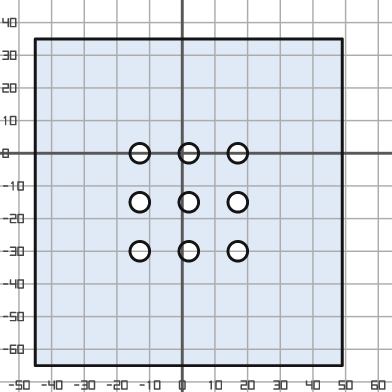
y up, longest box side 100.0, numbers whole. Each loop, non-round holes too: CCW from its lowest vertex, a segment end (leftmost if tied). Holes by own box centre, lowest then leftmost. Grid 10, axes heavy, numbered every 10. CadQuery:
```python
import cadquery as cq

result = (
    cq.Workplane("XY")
    .moveTo(-45.0, -65.0)
    .lineTo(49.0, -65.0)
    .lineTo(49.0, 35.0)
    .lineTo(-45.0, 35.0)
    .close()
    .moveTo(-13.0, -30.0)
    .circle(3.0)
    .moveTo(2.0, -30.0)
    .circle(3.0)
    .moveTo(17.0, -30.0)
    .circle(3.0)
    .moveTo(-13.0, -15.0)
    .circle(3.0)
    .moveTo(2.0, -15.0)
    .circle(3.0)
    .moveTo(17.0, -15.0)
    .circle(3.0)
    .moveTo(-13.0, 0.0)
    .circle(3.0)
    .moveTo(2.0, 0.0)
    .circle(3.0)
    .moveTo(17.0, 0.0)
    .circle(3.0)
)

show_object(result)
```